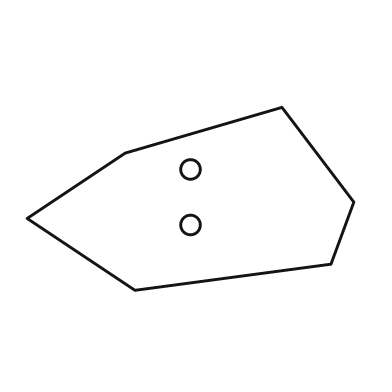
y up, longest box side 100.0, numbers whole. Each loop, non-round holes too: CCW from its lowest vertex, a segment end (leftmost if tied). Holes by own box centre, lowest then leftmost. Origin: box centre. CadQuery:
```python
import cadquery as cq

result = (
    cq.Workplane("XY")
    .moveTo(-17.0, -28.0)
    .lineTo(43.0, -20.0)
    .lineTo(50.0, -1.0)
    .lineTo(28.0, 28.0)
    .lineTo(-20.0, 14.0)
    .lineTo(-50.0, -6.0)
    .close()
    .moveTo(0.0, -8.0)
    .circle(3.0)
    .moveTo(0.0, 9.0)
    .circle(3.0)
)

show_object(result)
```